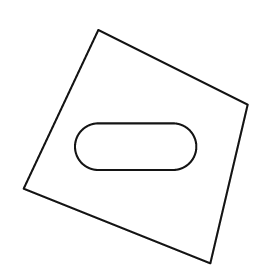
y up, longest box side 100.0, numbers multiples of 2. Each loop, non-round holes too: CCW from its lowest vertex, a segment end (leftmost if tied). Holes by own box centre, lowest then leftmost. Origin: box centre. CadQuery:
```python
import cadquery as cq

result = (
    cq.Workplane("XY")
    .moveTo(32.0, -50.0)
    .lineTo(48.0, 18.0)
    .lineTo(-16.0, 50.0)
    .lineTo(-48.0, -18.0)
    .close()
    .moveTo(-16.0, -10.0)
    .lineTo(16.0, -10.0)
    .threePointArc((26.0, 0.0), (16.0, 10.0))
    .lineTo(-16.0, 10.0)
    .threePointArc((-26.0, 0.0), (-16.0, -10.0))
    .close()
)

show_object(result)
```